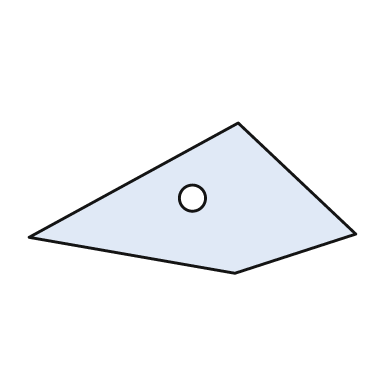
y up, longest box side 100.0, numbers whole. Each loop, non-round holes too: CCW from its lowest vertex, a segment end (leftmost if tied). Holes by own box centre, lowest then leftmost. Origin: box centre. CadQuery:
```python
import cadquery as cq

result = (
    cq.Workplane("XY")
    .moveTo(13.0, -23.0)
    .lineTo(50.0, -11.0)
    .lineTo(14.0, 23.0)
    .lineTo(-50.0, -12.0)
    .close()
    .moveTo(0.0, 0.0)
    .circle(4.0)
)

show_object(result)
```